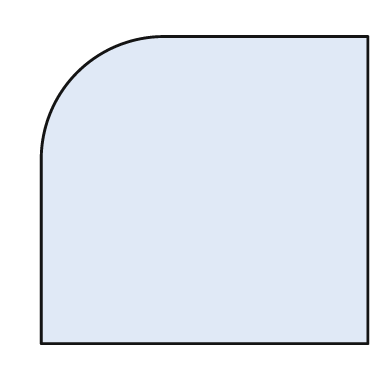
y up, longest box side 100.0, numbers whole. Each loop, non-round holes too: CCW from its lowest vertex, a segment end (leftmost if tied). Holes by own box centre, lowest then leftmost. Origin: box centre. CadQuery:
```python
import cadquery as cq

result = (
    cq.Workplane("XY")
    .moveTo(-50.0, -47.0)
    .lineTo(50.0, -47.0)
    .lineTo(50.0, 47.0)
    .lineTo(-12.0, 47.0)
    .threePointArc((-39.0, 36.0), (-50.0, 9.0))
    .close()
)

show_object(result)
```